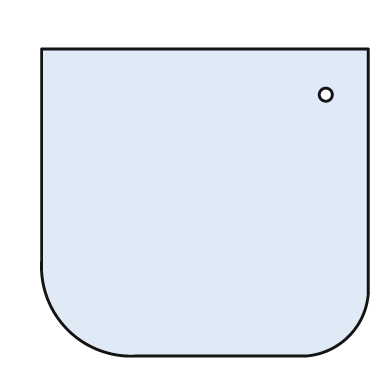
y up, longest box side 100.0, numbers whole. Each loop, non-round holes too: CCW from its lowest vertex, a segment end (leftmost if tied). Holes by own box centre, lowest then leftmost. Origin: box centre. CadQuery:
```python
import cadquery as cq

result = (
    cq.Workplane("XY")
    .moveTo(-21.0, -47.0)
    .lineTo(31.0, -47.0)
    .threePointArc((44.0, -41.0), (50.0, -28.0))
    .lineTo(50.0, 47.0)
    .lineTo(-50.0, 47.0)
    .lineTo(-50.0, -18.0)
    .threePointArc((-42.0, -39.0), (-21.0, -47.0))
    .close()
    .moveTo(37.0, 33.0)
    .circle(2.0)
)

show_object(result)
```